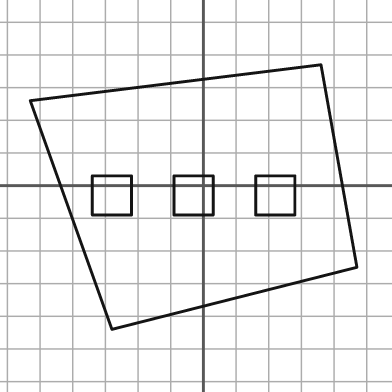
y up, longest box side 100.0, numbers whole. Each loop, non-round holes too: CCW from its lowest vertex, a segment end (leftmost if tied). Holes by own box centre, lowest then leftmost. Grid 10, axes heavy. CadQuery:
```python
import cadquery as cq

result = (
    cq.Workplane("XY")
    .moveTo(-28.0, -44.0)
    .lineTo(47.0, -25.0)
    .lineTo(36.0, 37.0)
    .lineTo(-53.0, 26.0)
    .close()
    .moveTo(-34.0, -9.0)
    .lineTo(-22.0, -9.0)
    .lineTo(-22.0, 3.0)
    .lineTo(-34.0, 3.0)
    .close()
    .moveTo(-9.0, -9.0)
    .lineTo(3.0, -9.0)
    .lineTo(3.0, 3.0)
    .lineTo(-9.0, 3.0)
    .close()
    .moveTo(16.0, -9.0)
    .lineTo(28.0, -9.0)
    .lineTo(28.0, 3.0)
    .lineTo(16.0, 3.0)
    .close()
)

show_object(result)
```